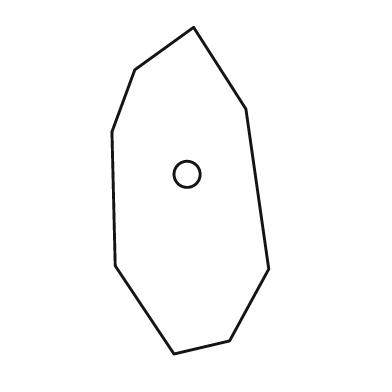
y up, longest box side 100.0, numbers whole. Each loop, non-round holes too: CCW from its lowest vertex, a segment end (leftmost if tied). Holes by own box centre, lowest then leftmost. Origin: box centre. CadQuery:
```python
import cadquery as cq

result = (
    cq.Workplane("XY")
    .moveTo(-5.0, -50.0)
    .lineTo(12.0, -46.0)
    .lineTo(24.0, -24.0)
    .lineTo(17.0, 25.0)
    .lineTo(1.0, 50.0)
    .lineTo(-17.0, 37.0)
    .lineTo(-24.0, 18.0)
    .lineTo(-23.0, -23.0)
    .close()
    .moveTo(-1.0, 5.0)
    .circle(4.0)
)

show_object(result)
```